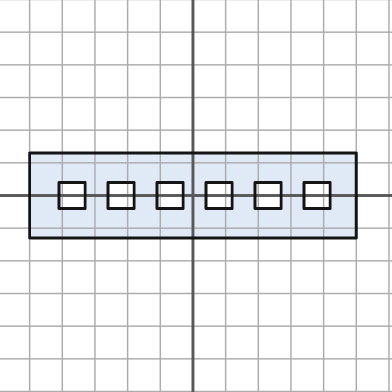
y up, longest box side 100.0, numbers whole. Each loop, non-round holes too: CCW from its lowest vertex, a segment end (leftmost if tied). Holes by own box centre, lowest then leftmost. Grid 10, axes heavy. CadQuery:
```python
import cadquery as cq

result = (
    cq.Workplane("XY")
    .moveTo(-50.0, -13.0)
    .lineTo(50.0, -13.0)
    .lineTo(50.0, 13.0)
    .lineTo(-50.0, 13.0)
    .close()
    .moveTo(-41.0, -4.0)
    .lineTo(-33.0, -4.0)
    .lineTo(-33.0, 4.0)
    .lineTo(-41.0, 4.0)
    .close()
    .moveTo(-26.0, -4.0)
    .lineTo(-18.0, -4.0)
    .lineTo(-18.0, 4.0)
    .lineTo(-26.0, 4.0)
    .close()
    .moveTo(-11.0, -4.0)
    .lineTo(-3.0, -4.0)
    .lineTo(-3.0, 4.0)
    .lineTo(-11.0, 4.0)
    .close()
    .moveTo(4.0, -4.0)
    .lineTo(12.0, -4.0)
    .lineTo(12.0, 4.0)
    .lineTo(4.0, 4.0)
    .close()
    .moveTo(19.0, -4.0)
    .lineTo(27.0, -4.0)
    .lineTo(27.0, 4.0)
    .lineTo(19.0, 4.0)
    .close()
    .moveTo(34.0, -4.0)
    .lineTo(42.0, -4.0)
    .lineTo(42.0, 4.0)
    .lineTo(34.0, 4.0)
    .close()
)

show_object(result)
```